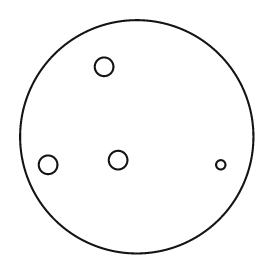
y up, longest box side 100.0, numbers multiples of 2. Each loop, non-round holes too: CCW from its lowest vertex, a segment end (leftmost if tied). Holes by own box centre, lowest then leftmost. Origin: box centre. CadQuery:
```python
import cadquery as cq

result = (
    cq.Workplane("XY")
    .moveTo(0.0, 0.0)
    .circle(50.0)
    .moveTo(-38.0, -12.0)
    .circle(4.0)
    .moveTo(36.0, -12.0)
    .circle(2.0)
    .moveTo(-8.0, -10.0)
    .circle(4.0)
    .moveTo(-14.0, 30.0)
    .circle(4.0)
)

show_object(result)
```